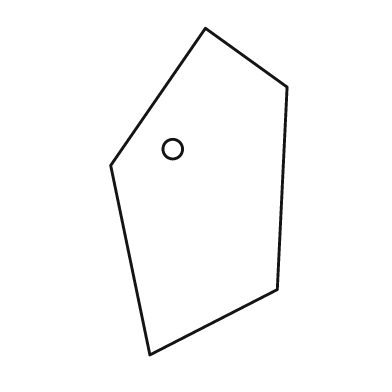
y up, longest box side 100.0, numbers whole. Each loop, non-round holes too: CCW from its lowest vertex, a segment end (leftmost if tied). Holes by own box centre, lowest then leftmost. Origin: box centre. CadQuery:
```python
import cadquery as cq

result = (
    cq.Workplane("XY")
    .moveTo(-15.0, -50.0)
    .lineTo(24.0, -30.0)
    .lineTo(27.0, 32.0)
    .lineTo(2.0, 50.0)
    .lineTo(-27.0, 8.0)
    .close()
    .moveTo(-8.0, 13.0)
    .circle(3.0)
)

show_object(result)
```